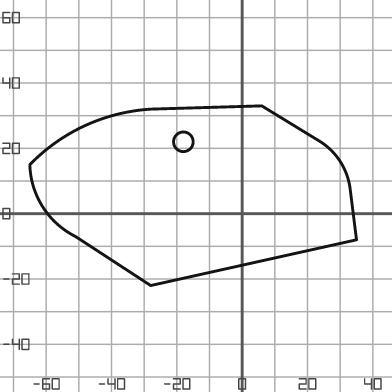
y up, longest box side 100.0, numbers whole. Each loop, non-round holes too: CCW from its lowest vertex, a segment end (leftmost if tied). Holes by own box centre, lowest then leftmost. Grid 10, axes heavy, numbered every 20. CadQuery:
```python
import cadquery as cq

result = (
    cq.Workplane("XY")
    .moveTo(-28.0, -22.0)
    .lineTo(35.0, -8.0)
    .lineTo(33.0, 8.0)
    .threePointArc((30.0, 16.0), (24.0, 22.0))
    .lineTo(6.0, 33.0)
    .lineTo(-28.0, 32.0)
    .threePointArc((-48.0, 27.0), (-65.0, 15.0))
    .threePointArc((-61.0, 2.0), (-51.0, -7.0))
    .close()
    .moveTo(-18.0, 22.0)
    .circle(3.0)
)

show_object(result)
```